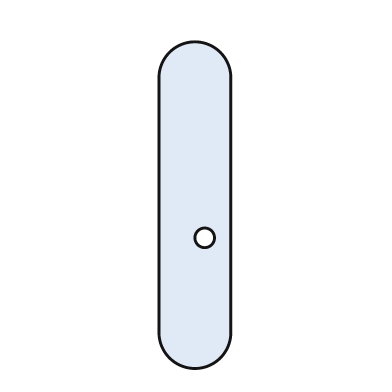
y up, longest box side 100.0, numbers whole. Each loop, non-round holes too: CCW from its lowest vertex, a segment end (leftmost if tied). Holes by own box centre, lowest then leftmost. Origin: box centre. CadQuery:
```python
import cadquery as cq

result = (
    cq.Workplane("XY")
    .moveTo(-11.0, -39.0)
    .threePointArc((0.0, -50.0), (11.0, -39.0))
    .lineTo(11.0, 39.0)
    .threePointArc((0.0, 50.0), (-11.0, 39.0))
    .close()
    .moveTo(3.0, -10.0)
    .circle(3.0)
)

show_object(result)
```